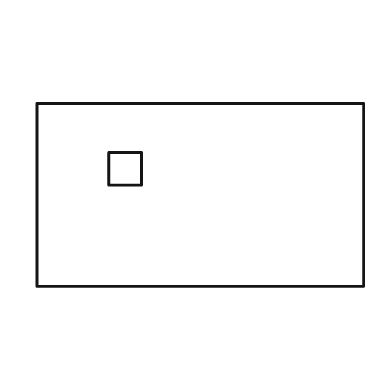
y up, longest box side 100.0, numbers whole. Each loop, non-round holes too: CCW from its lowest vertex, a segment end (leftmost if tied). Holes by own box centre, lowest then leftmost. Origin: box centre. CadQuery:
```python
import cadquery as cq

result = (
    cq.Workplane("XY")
    .moveTo(-50.0, -28.0)
    .lineTo(50.0, -28.0)
    .lineTo(50.0, 28.0)
    .lineTo(-50.0, 28.0)
    .close()
    .moveTo(-28.0, 3.0)
    .lineTo(-18.0, 3.0)
    .lineTo(-18.0, 13.0)
    .lineTo(-28.0, 13.0)
    .close()
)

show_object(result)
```